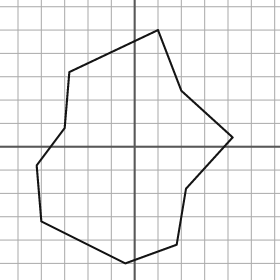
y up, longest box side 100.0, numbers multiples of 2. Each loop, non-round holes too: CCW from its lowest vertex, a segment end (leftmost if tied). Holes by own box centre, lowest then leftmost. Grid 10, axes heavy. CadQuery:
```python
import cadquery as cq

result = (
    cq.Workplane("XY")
    .moveTo(-4.0, -50.0)
    .lineTo(18.0, -42.0)
    .lineTo(22.0, -18.0)
    .lineTo(42.0, 4.0)
    .lineTo(20.0, 24.0)
    .lineTo(10.0, 50.0)
    .lineTo(-28.0, 32.0)
    .lineTo(-30.0, 8.0)
    .lineTo(-42.0, -8.0)
    .lineTo(-40.0, -32.0)
    .close()
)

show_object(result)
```